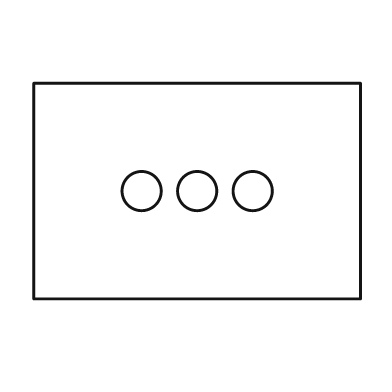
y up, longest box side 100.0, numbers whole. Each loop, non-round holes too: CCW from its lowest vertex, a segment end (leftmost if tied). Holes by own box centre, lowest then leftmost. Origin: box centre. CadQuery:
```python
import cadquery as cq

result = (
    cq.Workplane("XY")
    .moveTo(-50.0, -33.0)
    .lineTo(50.0, -33.0)
    .lineTo(50.0, 33.0)
    .lineTo(-50.0, 33.0)
    .close()
    .moveTo(-17.0, 0.0)
    .circle(6.0)
    .moveTo(0.0, 0.0)
    .circle(6.0)
    .moveTo(17.0, 0.0)
    .circle(6.0)
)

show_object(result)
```